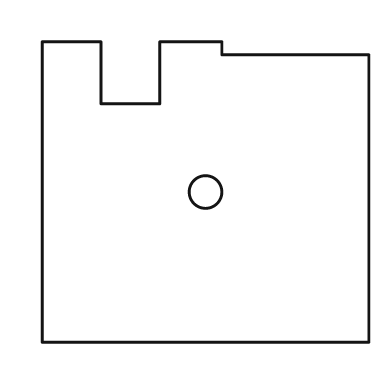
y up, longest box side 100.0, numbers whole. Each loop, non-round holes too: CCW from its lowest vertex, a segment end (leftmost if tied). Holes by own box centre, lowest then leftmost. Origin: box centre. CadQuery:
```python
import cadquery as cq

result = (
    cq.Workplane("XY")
    .moveTo(-50.0, -46.0)
    .lineTo(50.0, -46.0)
    .lineTo(50.0, 42.0)
    .lineTo(5.0, 42.0)
    .lineTo(5.0, 46.0)
    .lineTo(-14.0, 46.0)
    .lineTo(-14.0, 27.0)
    .lineTo(-32.0, 27.0)
    .lineTo(-32.0, 46.0)
    .lineTo(-50.0, 46.0)
    .close()
    .moveTo(0.0, 0.0)
    .circle(5.0)
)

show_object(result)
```